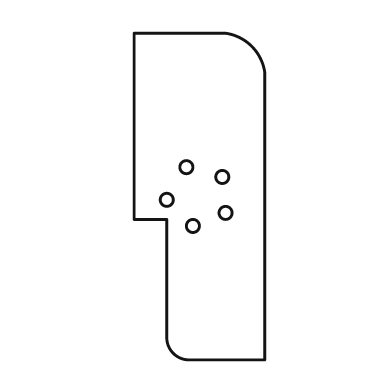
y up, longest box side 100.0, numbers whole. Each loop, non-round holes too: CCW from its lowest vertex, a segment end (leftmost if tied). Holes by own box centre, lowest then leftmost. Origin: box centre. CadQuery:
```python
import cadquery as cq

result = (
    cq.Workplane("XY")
    .moveTo(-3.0, -50.0)
    .lineTo(20.0, -50.0)
    .lineTo(20.0, 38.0)
    .threePointArc((16.0, 46.0), (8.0, 50.0))
    .lineTo(-20.0, 50.0)
    .lineTo(-20.0, -7.0)
    .lineTo(-10.0, -7.0)
    .lineTo(-10.0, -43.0)
    .threePointArc((-8.0, -48.0), (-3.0, -50.0))
    .close()
    .moveTo(-2.0, -9.0)
    .circle(2.0)
    .moveTo(8.0, -5.0)
    .circle(2.0)
    .moveTo(-10.0, -1.0)
    .circle(2.0)
    .moveTo(7.0, 6.0)
    .circle(2.0)
    .moveTo(-4.0, 9.0)
    .circle(2.0)
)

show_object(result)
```